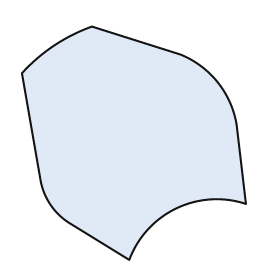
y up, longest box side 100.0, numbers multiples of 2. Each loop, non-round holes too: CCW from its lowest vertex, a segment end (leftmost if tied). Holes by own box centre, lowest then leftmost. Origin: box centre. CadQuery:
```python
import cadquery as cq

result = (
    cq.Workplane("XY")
    .moveTo(-2.0, -50.0)
    .threePointArc((18.0, -28.0), (48.0, -26.0))
    .lineTo(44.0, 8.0)
    .threePointArc((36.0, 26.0), (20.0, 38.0))
    .lineTo(-18.0, 50.0)
    .threePointArc((-34.0, 42.0), (-48.0, 30.0))
    .lineTo(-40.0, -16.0)
    .threePointArc((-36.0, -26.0), (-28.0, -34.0))
    .close()
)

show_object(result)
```